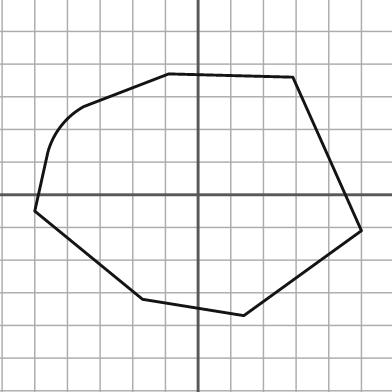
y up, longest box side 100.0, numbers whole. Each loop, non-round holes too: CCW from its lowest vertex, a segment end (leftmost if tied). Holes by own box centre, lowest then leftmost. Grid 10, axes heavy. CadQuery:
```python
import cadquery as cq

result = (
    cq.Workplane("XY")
    .moveTo(14.0, -37.0)
    .lineTo(50.0, -11.0)
    .lineTo(29.0, 36.0)
    .lineTo(-9.0, 37.0)
    .lineTo(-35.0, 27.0)
    .threePointArc((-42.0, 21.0), (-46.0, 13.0))
    .lineTo(-50.0, -5.0)
    .lineTo(-17.0, -32.0)
    .close()
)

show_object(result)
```